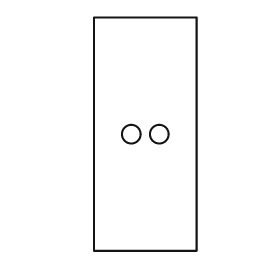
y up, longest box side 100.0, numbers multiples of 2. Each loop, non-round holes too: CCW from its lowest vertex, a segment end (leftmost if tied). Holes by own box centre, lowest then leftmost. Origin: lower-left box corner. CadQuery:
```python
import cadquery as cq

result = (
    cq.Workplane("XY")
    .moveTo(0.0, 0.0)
    .lineTo(44.0, 0.0)
    .lineTo(44.0, 100.0)
    .lineTo(0.0, 100.0)
    .close()
    .moveTo(16.0, 50.0)
    .circle(4.0)
    .moveTo(28.0, 50.0)
    .circle(4.0)
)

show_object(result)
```